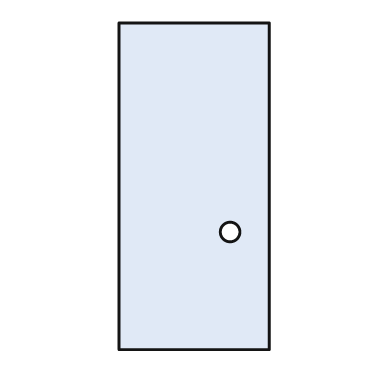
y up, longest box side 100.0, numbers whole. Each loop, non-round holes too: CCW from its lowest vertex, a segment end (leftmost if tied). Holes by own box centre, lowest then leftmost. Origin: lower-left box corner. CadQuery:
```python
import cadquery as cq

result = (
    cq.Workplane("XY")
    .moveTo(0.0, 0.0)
    .lineTo(46.0, 0.0)
    .lineTo(46.0, 100.0)
    .lineTo(0.0, 100.0)
    .close()
    .moveTo(34.0, 36.0)
    .circle(3.0)
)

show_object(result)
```